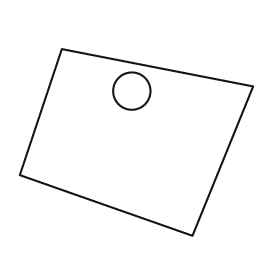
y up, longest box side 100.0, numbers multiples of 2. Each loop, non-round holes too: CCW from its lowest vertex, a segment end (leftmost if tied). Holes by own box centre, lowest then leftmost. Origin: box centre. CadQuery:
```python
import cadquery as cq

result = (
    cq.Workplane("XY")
    .moveTo(24.0, -40.0)
    .lineTo(50.0, 24.0)
    .lineTo(-32.0, 40.0)
    .lineTo(-50.0, -14.0)
    .close()
    .moveTo(-2.0, 22.0)
    .circle(8.0)
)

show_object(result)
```